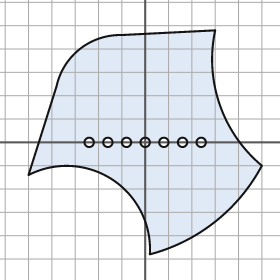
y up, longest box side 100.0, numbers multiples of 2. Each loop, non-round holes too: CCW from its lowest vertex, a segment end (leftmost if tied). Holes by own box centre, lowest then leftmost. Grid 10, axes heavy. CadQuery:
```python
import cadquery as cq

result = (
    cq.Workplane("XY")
    .moveTo(2.0, -48.0)
    .threePointArc((30.0, -34.0), (50.0, -10.0))
    .threePointArc((32.0, 16.0), (30.0, 48.0))
    .lineTo(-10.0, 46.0)
    .threePointArc((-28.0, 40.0), (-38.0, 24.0))
    .lineTo(-50.0, -14.0)
    .threePointArc((-14.0, -16.0), (2.0, -48.0))
    .close()
    .moveTo(-24.0, 0.0)
    .circle(2.0)
    .moveTo(-16.0, 0.0)
    .circle(2.0)
    .moveTo(-8.0, 0.0)
    .circle(2.0)
    .moveTo(0.0, 0.0)
    .circle(2.0)
    .moveTo(8.0, 0.0)
    .circle(2.0)
    .moveTo(16.0, 0.0)
    .circle(2.0)
    .moveTo(24.0, 0.0)
    .circle(2.0)
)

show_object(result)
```